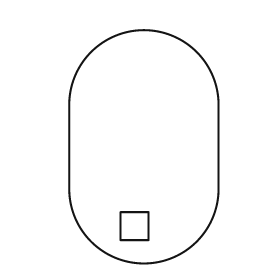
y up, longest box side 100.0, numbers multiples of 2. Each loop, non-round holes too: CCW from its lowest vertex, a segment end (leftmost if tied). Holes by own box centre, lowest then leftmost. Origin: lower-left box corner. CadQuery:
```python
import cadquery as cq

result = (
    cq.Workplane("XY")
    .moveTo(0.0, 32.0)
    .threePointArc((32.0, 0.0), (64.0, 32.0))
    .lineTo(64.0, 68.0)
    .threePointArc((32.0, 100.0), (0.0, 68.0))
    .close()
    .moveTo(22.0, 10.0)
    .lineTo(34.0, 10.0)
    .lineTo(34.0, 22.0)
    .lineTo(22.0, 22.0)
    .close()
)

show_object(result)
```